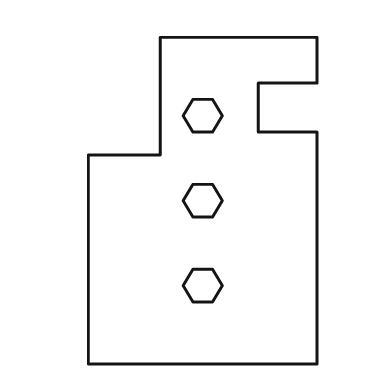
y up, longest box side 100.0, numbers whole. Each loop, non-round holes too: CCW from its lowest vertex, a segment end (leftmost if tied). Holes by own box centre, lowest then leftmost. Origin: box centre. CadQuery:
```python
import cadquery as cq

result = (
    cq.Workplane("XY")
    .moveTo(-35.0, -50.0)
    .lineTo(35.0, -50.0)
    .lineTo(35.0, 21.0)
    .lineTo(17.0, 21.0)
    .lineTo(17.0, 36.0)
    .lineTo(35.0, 36.0)
    .lineTo(35.0, 50.0)
    .lineTo(-13.0, 50.0)
    .lineTo(-13.0, 14.0)
    .lineTo(-35.0, 14.0)
    .close()
    .moveTo(-3.0, -31.0)
    .lineTo(3.0, -31.0)
    .lineTo(6.0, -26.0)
    .lineTo(3.0, -21.0)
    .lineTo(-3.0, -21.0)
    .lineTo(-6.0, -26.0)
    .close()
    .moveTo(-3.0, -5.0)
    .lineTo(3.0, -5.0)
    .lineTo(6.0, 0.0)
    .lineTo(3.0, 5.0)
    .lineTo(-3.0, 5.0)
    .lineTo(-6.0, 0.0)
    .close()
    .moveTo(-3.0, 21.0)
    .lineTo(3.0, 21.0)
    .lineTo(6.0, 26.0)
    .lineTo(3.0, 31.0)
    .lineTo(-3.0, 31.0)
    .lineTo(-6.0, 26.0)
    .close()
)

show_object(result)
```